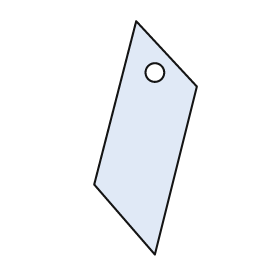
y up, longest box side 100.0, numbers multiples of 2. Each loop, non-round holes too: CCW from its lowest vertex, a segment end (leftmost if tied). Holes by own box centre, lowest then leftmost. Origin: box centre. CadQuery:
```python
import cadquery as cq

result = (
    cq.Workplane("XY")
    .moveTo(4.0, -50.0)
    .lineTo(22.0, 22.0)
    .lineTo(-4.0, 50.0)
    .lineTo(-22.0, -20.0)
    .close()
    .moveTo(4.0, 28.0)
    .circle(4.0)
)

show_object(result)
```